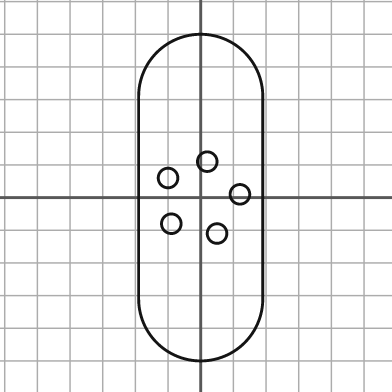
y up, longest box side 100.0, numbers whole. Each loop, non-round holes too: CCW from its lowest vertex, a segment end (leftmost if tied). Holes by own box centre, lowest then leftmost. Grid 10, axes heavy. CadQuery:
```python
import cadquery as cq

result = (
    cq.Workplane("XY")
    .moveTo(-19.0, -31.0)
    .threePointArc((0.0, -50.0), (19.0, -31.0))
    .lineTo(19.0, 31.0)
    .threePointArc((0.0, 50.0), (-19.0, 31.0))
    .close()
    .moveTo(5.0, -11.0)
    .circle(3.0)
    .moveTo(-9.0, -8.0)
    .circle(3.0)
    .moveTo(12.0, 1.0)
    .circle(3.0)
    .moveTo(-10.0, 6.0)
    .circle(3.0)
    .moveTo(2.0, 11.0)
    .circle(3.0)
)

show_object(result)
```